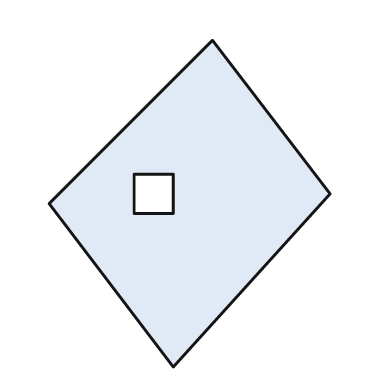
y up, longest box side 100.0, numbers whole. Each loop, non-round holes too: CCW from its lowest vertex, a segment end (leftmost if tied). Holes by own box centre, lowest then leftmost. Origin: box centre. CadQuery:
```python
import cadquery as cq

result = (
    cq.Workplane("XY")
    .moveTo(-5.0, -50.0)
    .lineTo(43.0, 3.0)
    .lineTo(7.0, 50.0)
    .lineTo(-43.0, 0.0)
    .close()
    .moveTo(-17.0, -3.0)
    .lineTo(-5.0, -3.0)
    .lineTo(-5.0, 9.0)
    .lineTo(-17.0, 9.0)
    .close()
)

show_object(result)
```